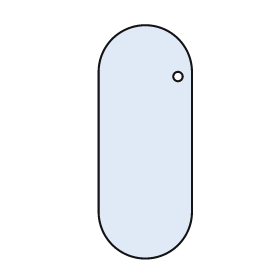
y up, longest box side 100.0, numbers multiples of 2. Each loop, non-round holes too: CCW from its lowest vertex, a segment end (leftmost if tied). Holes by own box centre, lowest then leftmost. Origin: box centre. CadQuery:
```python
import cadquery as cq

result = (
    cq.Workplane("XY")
    .moveTo(-20.0, -30.0)
    .threePointArc((0.0, -50.0), (20.0, -30.0))
    .lineTo(20.0, 30.0)
    .threePointArc((0.0, 50.0), (-20.0, 30.0))
    .close()
    .moveTo(14.0, 28.0)
    .circle(2.0)
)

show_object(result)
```